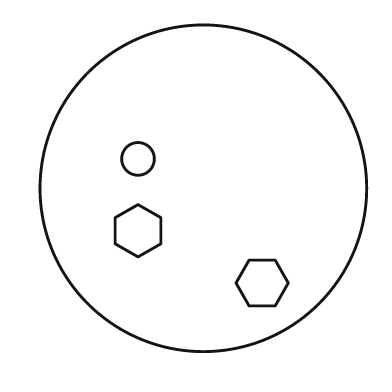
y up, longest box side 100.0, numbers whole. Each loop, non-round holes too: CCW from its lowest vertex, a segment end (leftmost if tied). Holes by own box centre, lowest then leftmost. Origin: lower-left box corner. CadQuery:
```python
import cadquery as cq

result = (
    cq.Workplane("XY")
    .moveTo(50.0, 50.0)
    .circle(50.0)
    .moveTo(64.0, 14.0)
    .lineTo(72.0, 14.0)
    .lineTo(76.0, 21.0)
    .lineTo(72.0, 28.0)
    .lineTo(64.0, 28.0)
    .lineTo(60.0, 21.0)
    .close()
    .moveTo(30.0, 29.0)
    .lineTo(37.0, 33.0)
    .lineTo(37.0, 41.0)
    .lineTo(30.0, 45.0)
    .lineTo(23.0, 41.0)
    .lineTo(23.0, 33.0)
    .close()
    .moveTo(30.0, 59.0)
    .circle(5.0)
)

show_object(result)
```